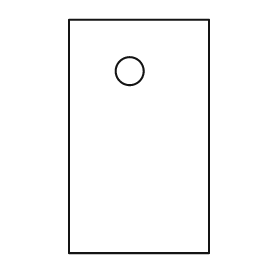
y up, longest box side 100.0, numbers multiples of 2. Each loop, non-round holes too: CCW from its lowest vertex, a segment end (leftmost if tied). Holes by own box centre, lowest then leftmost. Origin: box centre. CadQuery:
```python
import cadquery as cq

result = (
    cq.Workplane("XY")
    .moveTo(-30.0, -50.0)
    .lineTo(30.0, -50.0)
    .lineTo(30.0, 50.0)
    .lineTo(-30.0, 50.0)
    .close()
    .moveTo(-4.0, 28.0)
    .circle(6.0)
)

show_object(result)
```